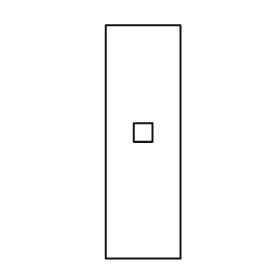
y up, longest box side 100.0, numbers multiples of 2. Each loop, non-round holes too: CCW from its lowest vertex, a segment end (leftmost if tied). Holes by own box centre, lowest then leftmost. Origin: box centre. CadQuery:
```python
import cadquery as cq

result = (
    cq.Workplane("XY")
    .moveTo(-16.0, -50.0)
    .lineTo(16.0, -50.0)
    .lineTo(16.0, 50.0)
    .lineTo(-16.0, 50.0)
    .close()
    .moveTo(-4.0, 0.0)
    .lineTo(4.0, 0.0)
    .lineTo(4.0, 8.0)
    .lineTo(-4.0, 8.0)
    .close()
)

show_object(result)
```